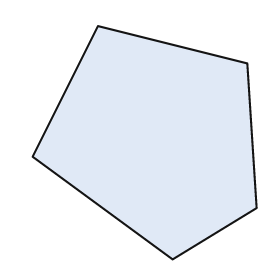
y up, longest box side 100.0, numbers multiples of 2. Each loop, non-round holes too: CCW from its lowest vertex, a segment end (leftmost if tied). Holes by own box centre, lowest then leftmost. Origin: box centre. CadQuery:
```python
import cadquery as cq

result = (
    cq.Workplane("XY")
    .moveTo(12.0, -50.0)
    .lineTo(48.0, -28.0)
    .lineTo(44.0, 34.0)
    .lineTo(-20.0, 50.0)
    .lineTo(-48.0, -6.0)
    .close()
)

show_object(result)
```